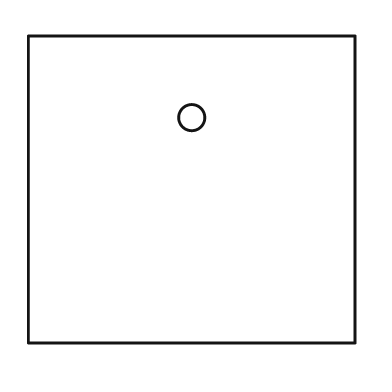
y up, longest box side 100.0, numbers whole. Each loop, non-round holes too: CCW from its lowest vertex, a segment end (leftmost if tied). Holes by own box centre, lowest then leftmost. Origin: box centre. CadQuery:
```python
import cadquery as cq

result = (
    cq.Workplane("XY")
    .moveTo(-50.0, -47.0)
    .lineTo(50.0, -47.0)
    .lineTo(50.0, 47.0)
    .lineTo(-50.0, 47.0)
    .close()
    .moveTo(0.0, 22.0)
    .circle(4.0)
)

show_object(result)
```